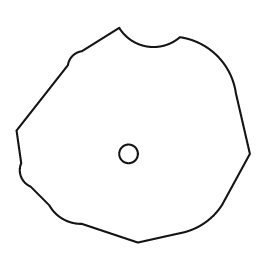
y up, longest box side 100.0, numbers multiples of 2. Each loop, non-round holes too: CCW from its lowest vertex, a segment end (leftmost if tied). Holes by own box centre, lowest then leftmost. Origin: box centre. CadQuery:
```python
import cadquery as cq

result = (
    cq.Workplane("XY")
    .moveTo(2.0, -46.0)
    .lineTo(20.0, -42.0)
    .threePointArc((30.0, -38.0), (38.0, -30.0))
    .lineTo(50.0, -8.0)
    .lineTo(44.0, 18.0)
    .threePointArc((36.0, 34.0), (20.0, 42.0))
    .threePointArc((6.0, 38.0), (-6.0, 46.0))
    .lineTo(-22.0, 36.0)
    .threePointArc((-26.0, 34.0), (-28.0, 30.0))
    .lineTo(-50.0, 2.0)
    .lineTo(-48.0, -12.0)
    .threePointArc((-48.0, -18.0), (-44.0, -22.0))
    .lineTo(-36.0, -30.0)
    .threePointArc((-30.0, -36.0), (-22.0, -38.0))
    .close()
    .moveTo(-2.0, -8.0)
    .circle(4.0)
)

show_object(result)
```